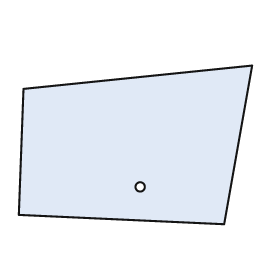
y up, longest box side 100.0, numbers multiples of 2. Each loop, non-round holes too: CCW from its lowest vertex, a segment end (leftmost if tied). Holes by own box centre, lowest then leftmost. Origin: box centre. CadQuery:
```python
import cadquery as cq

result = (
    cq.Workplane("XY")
    .moveTo(38.0, -34.0)
    .lineTo(50.0, 34.0)
    .lineTo(-48.0, 24.0)
    .lineTo(-50.0, -30.0)
    .close()
    .moveTo(2.0, -18.0)
    .circle(2.0)
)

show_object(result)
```